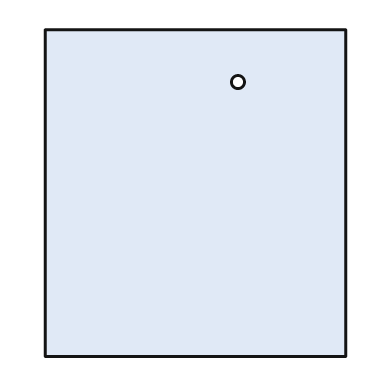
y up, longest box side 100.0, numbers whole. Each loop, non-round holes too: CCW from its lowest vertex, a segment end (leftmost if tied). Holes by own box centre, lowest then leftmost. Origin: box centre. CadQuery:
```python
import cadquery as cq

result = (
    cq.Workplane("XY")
    .moveTo(-46.0, -50.0)
    .lineTo(46.0, -50.0)
    .lineTo(46.0, 50.0)
    .lineTo(-46.0, 50.0)
    .close()
    .moveTo(13.0, 34.0)
    .circle(2.0)
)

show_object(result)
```